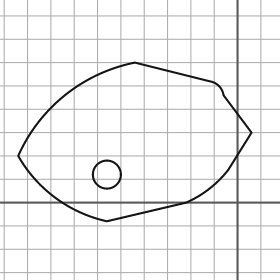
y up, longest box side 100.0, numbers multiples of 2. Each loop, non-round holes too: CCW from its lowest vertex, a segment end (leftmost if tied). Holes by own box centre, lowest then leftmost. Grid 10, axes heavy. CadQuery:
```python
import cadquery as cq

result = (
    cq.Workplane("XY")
    .moveTo(-56.0, -8.0)
    .lineTo(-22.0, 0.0)
    .threePointArc((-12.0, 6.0), (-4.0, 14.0))
    .lineTo(6.0, 30.0)
    .lineTo(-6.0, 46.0)
    .threePointArc((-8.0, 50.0), (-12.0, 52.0))
    .lineTo(-44.0, 60.0)
    .threePointArc((-74.0, 46.0), (-94.0, 20.0))
    .threePointArc((-78.0, 2.0), (-56.0, -8.0))
    .close()
    .moveTo(-56.0, 12.0)
    .circle(6.0)
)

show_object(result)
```